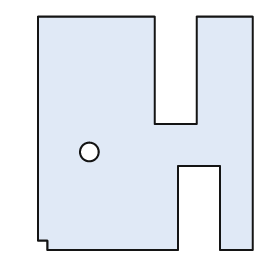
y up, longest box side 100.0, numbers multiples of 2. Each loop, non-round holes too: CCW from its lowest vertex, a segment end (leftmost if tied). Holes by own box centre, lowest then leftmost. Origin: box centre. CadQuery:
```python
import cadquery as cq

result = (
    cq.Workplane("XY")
    .moveTo(-42.0, -50.0)
    .lineTo(14.0, -50.0)
    .lineTo(14.0, -14.0)
    .lineTo(32.0, -14.0)
    .lineTo(32.0, -50.0)
    .lineTo(46.0, -50.0)
    .lineTo(46.0, 50.0)
    .lineTo(22.0, 50.0)
    .lineTo(22.0, 4.0)
    .lineTo(4.0, 4.0)
    .lineTo(4.0, 50.0)
    .lineTo(-46.0, 50.0)
    .lineTo(-46.0, -46.0)
    .lineTo(-42.0, -46.0)
    .close()
    .moveTo(-24.0, -8.0)
    .circle(4.0)
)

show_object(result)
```